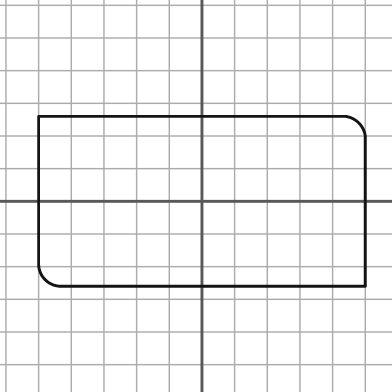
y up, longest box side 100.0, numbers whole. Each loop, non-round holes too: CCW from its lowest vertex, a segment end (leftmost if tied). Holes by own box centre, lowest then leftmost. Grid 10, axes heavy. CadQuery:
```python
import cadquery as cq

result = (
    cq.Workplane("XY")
    .moveTo(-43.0, -26.0)
    .lineTo(50.0, -26.0)
    .lineTo(50.0, 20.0)
    .threePointArc((48.0, 24.0), (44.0, 26.0))
    .lineTo(-50.0, 26.0)
    .lineTo(-50.0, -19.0)
    .threePointArc((-48.0, -24.0), (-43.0, -26.0))
    .close()
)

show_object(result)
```